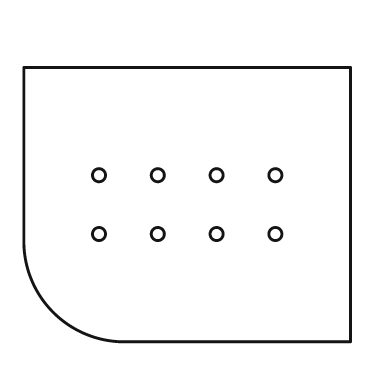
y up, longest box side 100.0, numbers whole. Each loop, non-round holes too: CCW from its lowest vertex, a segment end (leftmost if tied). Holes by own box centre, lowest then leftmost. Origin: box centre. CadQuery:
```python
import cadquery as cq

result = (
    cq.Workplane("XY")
    .moveTo(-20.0, -42.0)
    .lineTo(50.0, -42.0)
    .lineTo(50.0, 42.0)
    .lineTo(-50.0, 42.0)
    .lineTo(-50.0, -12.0)
    .threePointArc((-41.0, -33.0), (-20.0, -42.0))
    .close()
    .moveTo(-27.0, -9.0)
    .circle(2.0)
    .moveTo(-9.0, -9.0)
    .circle(2.0)
    .moveTo(9.0, -9.0)
    .circle(2.0)
    .moveTo(27.0, -9.0)
    .circle(2.0)
    .moveTo(-27.0, 9.0)
    .circle(2.0)
    .moveTo(-9.0, 9.0)
    .circle(2.0)
    .moveTo(9.0, 9.0)
    .circle(2.0)
    .moveTo(27.0, 9.0)
    .circle(2.0)
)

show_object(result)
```